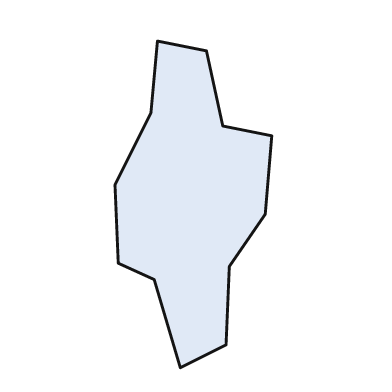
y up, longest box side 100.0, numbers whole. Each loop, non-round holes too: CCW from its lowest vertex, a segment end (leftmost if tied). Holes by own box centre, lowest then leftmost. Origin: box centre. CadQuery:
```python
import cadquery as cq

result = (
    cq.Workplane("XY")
    .moveTo(-4.0, -50.0)
    .lineTo(10.0, -43.0)
    .lineTo(11.0, -19.0)
    .lineTo(22.0, -3.0)
    .lineTo(24.0, 21.0)
    .lineTo(9.0, 24.0)
    .lineTo(4.0, 47.0)
    .lineTo(-11.0, 50.0)
    .lineTo(-13.0, 28.0)
    .lineTo(-24.0, 6.0)
    .lineTo(-23.0, -18.0)
    .lineTo(-12.0, -23.0)
    .close()
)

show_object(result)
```